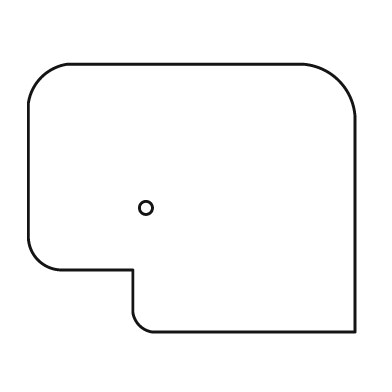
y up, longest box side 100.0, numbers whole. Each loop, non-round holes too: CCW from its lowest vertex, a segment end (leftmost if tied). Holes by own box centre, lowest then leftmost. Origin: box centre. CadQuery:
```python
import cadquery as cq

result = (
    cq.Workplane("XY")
    .moveTo(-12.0, -41.0)
    .lineTo(50.0, -41.0)
    .lineTo(50.0, 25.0)
    .threePointArc((45.0, 36.0), (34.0, 41.0))
    .lineTo(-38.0, 41.0)
    .threePointArc((-46.0, 37.0), (-50.0, 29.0))
    .lineTo(-50.0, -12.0)
    .threePointArc((-47.0, -19.0), (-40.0, -22.0))
    .lineTo(-18.0, -22.0)
    .lineTo(-18.0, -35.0)
    .threePointArc((-16.0, -39.0), (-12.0, -41.0))
    .close()
    .moveTo(-14.0, -3.0)
    .circle(2.0)
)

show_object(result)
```